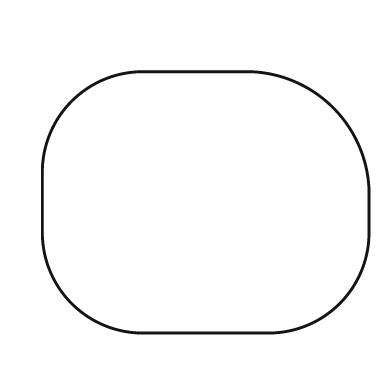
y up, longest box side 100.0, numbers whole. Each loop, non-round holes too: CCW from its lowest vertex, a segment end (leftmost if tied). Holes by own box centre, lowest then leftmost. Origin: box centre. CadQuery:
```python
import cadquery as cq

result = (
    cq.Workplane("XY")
    .moveTo(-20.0, -40.0)
    .lineTo(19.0, -40.0)
    .threePointArc((41.0, -31.0), (50.0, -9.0))
    .lineTo(50.0, 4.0)
    .threePointArc((39.0, 29.0), (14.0, 40.0))
    .lineTo(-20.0, 40.0)
    .threePointArc((-41.0, 31.0), (-50.0, 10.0))
    .lineTo(-50.0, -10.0)
    .threePointArc((-41.0, -31.0), (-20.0, -40.0))
    .close()
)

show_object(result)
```